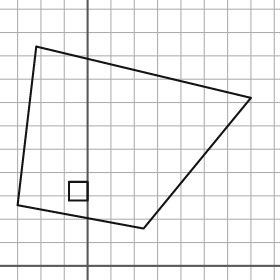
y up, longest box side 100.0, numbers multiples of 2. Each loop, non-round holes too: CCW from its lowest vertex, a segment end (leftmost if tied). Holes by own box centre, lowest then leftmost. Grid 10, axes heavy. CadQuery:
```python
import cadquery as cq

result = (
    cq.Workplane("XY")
    .moveTo(24.0, 16.0)
    .lineTo(70.0, 72.0)
    .lineTo(-22.0, 94.0)
    .lineTo(-30.0, 26.0)
    .close()
    .moveTo(-8.0, 28.0)
    .lineTo(0.0, 28.0)
    .lineTo(0.0, 36.0)
    .lineTo(-8.0, 36.0)
    .close()
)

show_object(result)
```